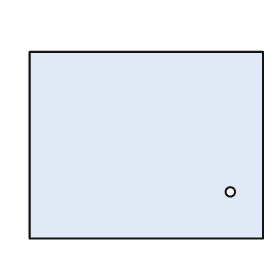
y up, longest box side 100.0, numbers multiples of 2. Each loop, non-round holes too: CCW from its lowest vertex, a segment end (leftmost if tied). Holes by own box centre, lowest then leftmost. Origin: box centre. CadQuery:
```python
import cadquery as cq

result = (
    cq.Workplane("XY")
    .moveTo(-50.0, -40.0)
    .lineTo(50.0, -40.0)
    .lineTo(50.0, 40.0)
    .lineTo(-50.0, 40.0)
    .close()
    .moveTo(36.0, -20.0)
    .circle(2.0)
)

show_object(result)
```